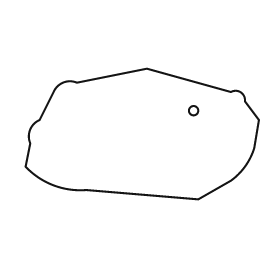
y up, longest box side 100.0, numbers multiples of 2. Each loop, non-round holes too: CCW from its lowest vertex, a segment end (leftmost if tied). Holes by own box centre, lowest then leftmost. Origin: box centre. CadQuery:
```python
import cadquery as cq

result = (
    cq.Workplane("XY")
    .moveTo(24.0, -28.0)
    .lineTo(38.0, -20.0)
    .threePointArc((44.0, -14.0), (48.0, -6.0))
    .lineTo(50.0, 6.0)
    .lineTo(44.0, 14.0)
    .threePointArc((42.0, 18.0), (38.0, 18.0))
    .lineTo(2.0, 28.0)
    .lineTo(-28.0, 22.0)
    .threePointArc((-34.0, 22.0), (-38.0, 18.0))
    .lineTo(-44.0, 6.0)
    .threePointArc((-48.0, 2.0), (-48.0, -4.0))
    .lineTo(-50.0, -14.0)
    .threePointArc((-38.0, -22.0), (-24.0, -24.0))
    .close()
    .moveTo(22.0, 10.0)
    .circle(2.0)
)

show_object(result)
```